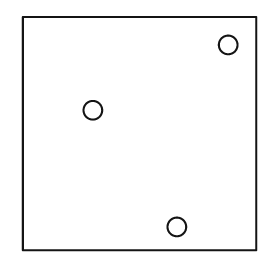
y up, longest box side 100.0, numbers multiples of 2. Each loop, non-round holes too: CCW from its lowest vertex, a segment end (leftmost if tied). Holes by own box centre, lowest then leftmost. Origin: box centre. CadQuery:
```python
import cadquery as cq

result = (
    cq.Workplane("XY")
    .moveTo(-50.0, -50.0)
    .lineTo(50.0, -50.0)
    .lineTo(50.0, 50.0)
    .lineTo(-50.0, 50.0)
    .close()
    .moveTo(16.0, -40.0)
    .circle(4.0)
    .moveTo(-20.0, 10.0)
    .circle(4.0)
    .moveTo(38.0, 38.0)
    .circle(4.0)
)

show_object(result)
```